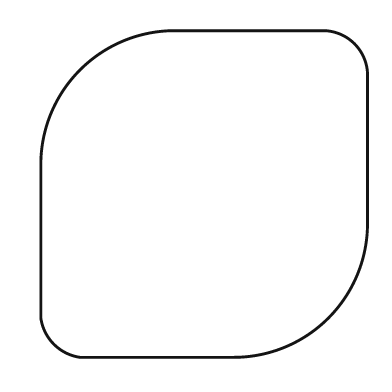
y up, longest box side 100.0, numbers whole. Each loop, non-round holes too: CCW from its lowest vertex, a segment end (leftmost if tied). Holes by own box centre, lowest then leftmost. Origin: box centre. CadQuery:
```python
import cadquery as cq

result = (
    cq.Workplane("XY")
    .moveTo(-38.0, -50.0)
    .lineTo(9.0, -50.0)
    .threePointArc((38.0, -38.0), (50.0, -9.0))
    .lineTo(50.0, 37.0)
    .threePointArc((46.0, 46.0), (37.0, 50.0))
    .lineTo(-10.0, 50.0)
    .threePointArc((-38.0, 38.0), (-50.0, 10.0))
    .lineTo(-50.0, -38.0)
    .threePointArc((-46.0, -46.0), (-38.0, -50.0))
    .close()
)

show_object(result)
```